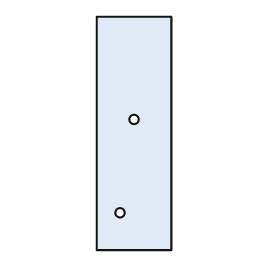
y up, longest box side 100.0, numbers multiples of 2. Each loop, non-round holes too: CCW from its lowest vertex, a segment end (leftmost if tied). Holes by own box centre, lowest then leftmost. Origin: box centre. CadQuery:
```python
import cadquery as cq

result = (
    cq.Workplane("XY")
    .moveTo(-16.0, -50.0)
    .lineTo(16.0, -50.0)
    .lineTo(16.0, 50.0)
    .lineTo(-16.0, 50.0)
    .close()
    .moveTo(-6.0, -34.0)
    .circle(2.0)
    .moveTo(0.0, 6.0)
    .circle(2.0)
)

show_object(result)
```